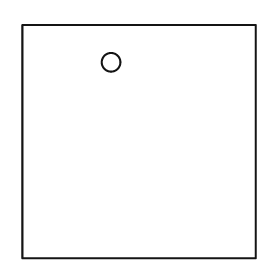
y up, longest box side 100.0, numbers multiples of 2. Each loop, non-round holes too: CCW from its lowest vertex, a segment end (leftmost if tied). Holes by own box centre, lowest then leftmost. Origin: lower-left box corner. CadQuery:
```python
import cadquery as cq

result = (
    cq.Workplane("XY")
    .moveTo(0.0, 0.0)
    .lineTo(100.0, 0.0)
    .lineTo(100.0, 100.0)
    .lineTo(0.0, 100.0)
    .close()
    .moveTo(38.0, 84.0)
    .circle(4.0)
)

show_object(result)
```